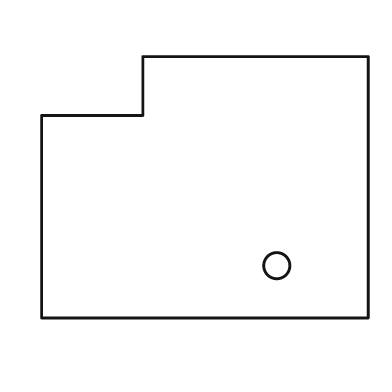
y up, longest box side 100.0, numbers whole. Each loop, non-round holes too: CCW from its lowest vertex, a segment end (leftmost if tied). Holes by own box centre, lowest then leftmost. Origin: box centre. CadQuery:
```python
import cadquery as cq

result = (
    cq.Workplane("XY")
    .moveTo(-50.0, -40.0)
    .lineTo(50.0, -40.0)
    .lineTo(50.0, 40.0)
    .lineTo(-19.0, 40.0)
    .lineTo(-19.0, 22.0)
    .lineTo(-50.0, 22.0)
    .close()
    .moveTo(22.0, -24.0)
    .circle(4.0)
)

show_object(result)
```